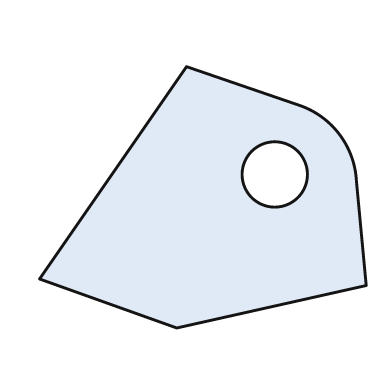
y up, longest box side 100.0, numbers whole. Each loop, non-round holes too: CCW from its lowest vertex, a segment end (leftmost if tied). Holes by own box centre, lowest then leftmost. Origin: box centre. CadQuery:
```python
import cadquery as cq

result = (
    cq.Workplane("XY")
    .moveTo(-8.0, -40.0)
    .lineTo(50.0, -27.0)
    .lineTo(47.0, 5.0)
    .threePointArc((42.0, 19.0), (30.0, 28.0))
    .lineTo(-5.0, 40.0)
    .lineTo(-50.0, -25.0)
    .close()
    .moveTo(22.0, 7.0)
    .circle(10.0)
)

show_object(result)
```